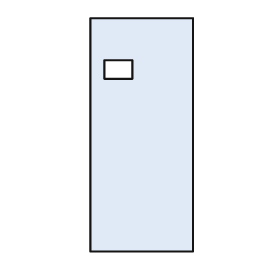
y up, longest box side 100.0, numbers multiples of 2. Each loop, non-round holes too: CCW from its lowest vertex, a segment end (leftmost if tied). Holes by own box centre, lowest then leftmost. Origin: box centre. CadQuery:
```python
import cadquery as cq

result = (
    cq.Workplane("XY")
    .moveTo(-22.0, -50.0)
    .lineTo(22.0, -50.0)
    .lineTo(22.0, 50.0)
    .lineTo(-22.0, 50.0)
    .close()
    .moveTo(-16.0, 24.0)
    .lineTo(-4.0, 24.0)
    .lineTo(-4.0, 32.0)
    .lineTo(-16.0, 32.0)
    .close()
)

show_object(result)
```